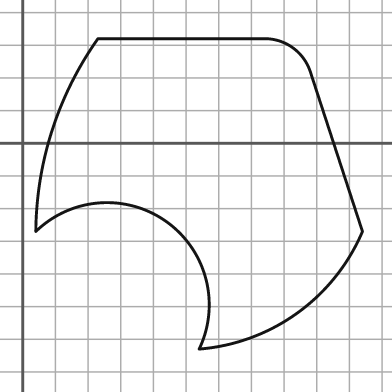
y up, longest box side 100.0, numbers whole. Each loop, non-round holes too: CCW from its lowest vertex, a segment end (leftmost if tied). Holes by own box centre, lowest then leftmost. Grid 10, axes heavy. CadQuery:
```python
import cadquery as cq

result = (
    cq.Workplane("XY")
    .moveTo(54.0, -63.0)
    .threePointArc((84.0, -52.0), (104.0, -27.0))
    .lineTo(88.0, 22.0)
    .threePointArc((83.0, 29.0), (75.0, 32.0))
    .lineTo(23.0, 32.0)
    .threePointArc((9.0, 4.0), (4.0, -27.0))
    .threePointArc((44.0, -24.0), (54.0, -63.0))
    .close()
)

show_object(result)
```